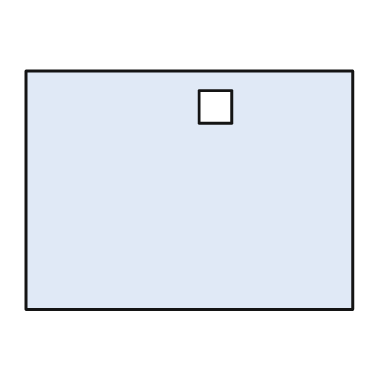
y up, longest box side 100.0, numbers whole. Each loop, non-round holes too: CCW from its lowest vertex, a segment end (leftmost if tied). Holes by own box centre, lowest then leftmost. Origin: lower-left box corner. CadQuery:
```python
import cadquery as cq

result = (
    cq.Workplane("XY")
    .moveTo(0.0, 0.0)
    .lineTo(100.0, 0.0)
    .lineTo(100.0, 73.0)
    .lineTo(0.0, 73.0)
    .close()
    .moveTo(53.0, 57.0)
    .lineTo(63.0, 57.0)
    .lineTo(63.0, 67.0)
    .lineTo(53.0, 67.0)
    .close()
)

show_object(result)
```